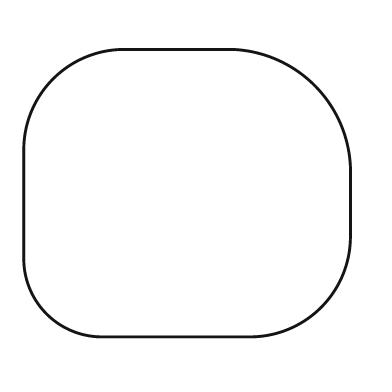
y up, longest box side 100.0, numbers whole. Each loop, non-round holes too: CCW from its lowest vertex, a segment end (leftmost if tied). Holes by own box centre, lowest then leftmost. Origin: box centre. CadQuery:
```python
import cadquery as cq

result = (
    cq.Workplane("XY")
    .moveTo(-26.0, -44.0)
    .lineTo(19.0, -44.0)
    .threePointArc((41.0, -35.0), (50.0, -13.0))
    .lineTo(50.0, 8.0)
    .threePointArc((39.0, 33.0), (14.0, 44.0))
    .lineTo(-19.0, 44.0)
    .threePointArc((-41.0, 35.0), (-50.0, 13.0))
    .lineTo(-50.0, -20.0)
    .threePointArc((-43.0, -37.0), (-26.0, -44.0))
    .close()
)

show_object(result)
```